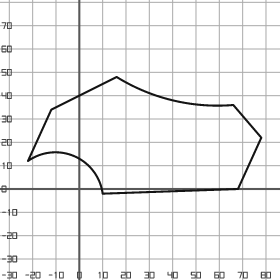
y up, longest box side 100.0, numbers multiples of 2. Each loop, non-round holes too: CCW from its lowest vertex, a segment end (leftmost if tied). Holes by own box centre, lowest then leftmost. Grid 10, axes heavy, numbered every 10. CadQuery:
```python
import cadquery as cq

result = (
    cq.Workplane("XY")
    .moveTo(10.0, -2.0)
    .lineTo(68.0, 0.0)
    .lineTo(78.0, 22.0)
    .lineTo(66.0, 36.0)
    .threePointArc((40.0, 38.0), (16.0, 48.0))
    .lineTo(-12.0, 34.0)
    .lineTo(-22.0, 12.0)
    .threePointArc((-2.0, 14.0), (10.0, -2.0))
    .close()
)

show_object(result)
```